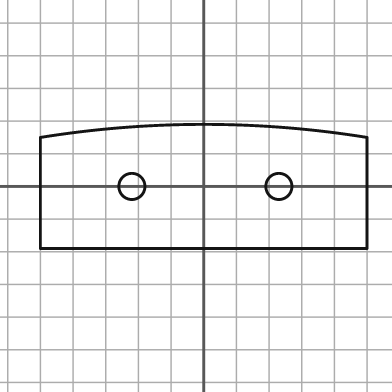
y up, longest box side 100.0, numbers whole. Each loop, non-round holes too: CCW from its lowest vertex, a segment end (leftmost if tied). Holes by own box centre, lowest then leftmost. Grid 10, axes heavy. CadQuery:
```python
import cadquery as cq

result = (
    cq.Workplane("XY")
    .moveTo(-50.0, -19.0)
    .lineTo(50.0, -19.0)
    .lineTo(50.0, 15.0)
    .threePointArc((0.0, 19.0), (-50.0, 15.0))
    .close()
    .moveTo(-22.0, 0.0)
    .circle(4.0)
    .moveTo(23.0, 0.0)
    .circle(4.0)
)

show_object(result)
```